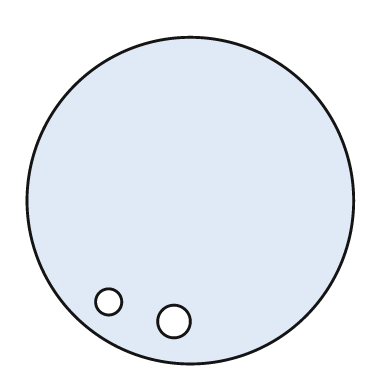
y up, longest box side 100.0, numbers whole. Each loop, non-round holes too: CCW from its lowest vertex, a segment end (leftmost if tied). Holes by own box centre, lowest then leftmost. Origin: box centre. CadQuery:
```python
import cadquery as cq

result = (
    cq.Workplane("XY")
    .moveTo(0.0, 0.0)
    .circle(50.0)
    .moveTo(-5.0, -37.0)
    .circle(5.0)
    .moveTo(-25.0, -31.0)
    .circle(4.0)
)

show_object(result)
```